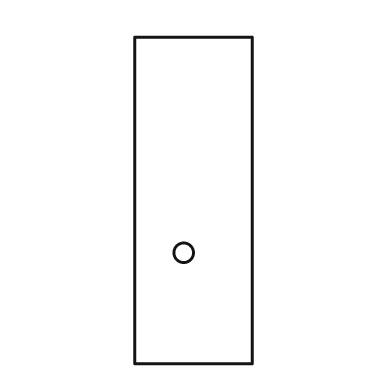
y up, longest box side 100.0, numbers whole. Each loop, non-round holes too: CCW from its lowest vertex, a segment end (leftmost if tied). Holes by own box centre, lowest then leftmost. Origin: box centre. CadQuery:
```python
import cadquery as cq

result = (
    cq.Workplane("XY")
    .moveTo(-18.0, -50.0)
    .lineTo(18.0, -50.0)
    .lineTo(18.0, 50.0)
    .lineTo(-18.0, 50.0)
    .close()
    .moveTo(-3.0, -16.0)
    .circle(3.0)
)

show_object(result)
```